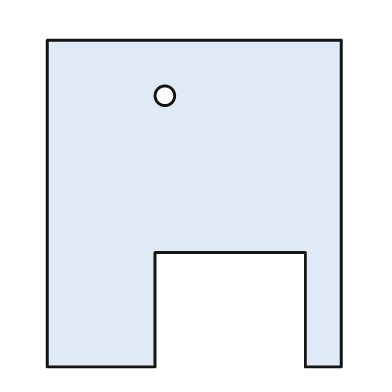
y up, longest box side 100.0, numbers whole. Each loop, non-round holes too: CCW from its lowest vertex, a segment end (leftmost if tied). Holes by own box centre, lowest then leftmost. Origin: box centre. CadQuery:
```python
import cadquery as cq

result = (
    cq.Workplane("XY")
    .moveTo(-45.0, -50.0)
    .lineTo(-12.0, -50.0)
    .lineTo(-12.0, -15.0)
    .lineTo(34.0, -15.0)
    .lineTo(34.0, -50.0)
    .lineTo(45.0, -50.0)
    .lineTo(45.0, 50.0)
    .lineTo(-45.0, 50.0)
    .close()
    .moveTo(-9.0, 33.0)
    .circle(3.0)
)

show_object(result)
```